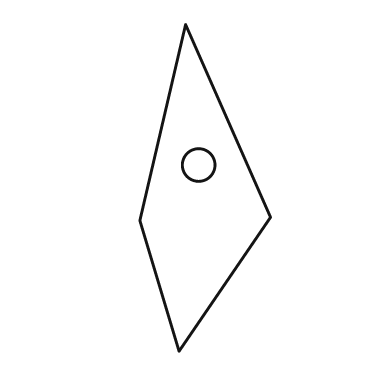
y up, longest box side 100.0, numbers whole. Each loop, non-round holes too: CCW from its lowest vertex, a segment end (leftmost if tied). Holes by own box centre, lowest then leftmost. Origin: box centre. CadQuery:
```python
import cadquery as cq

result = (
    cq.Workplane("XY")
    .moveTo(-8.0, -50.0)
    .lineTo(20.0, -9.0)
    .lineTo(-6.0, 50.0)
    .lineTo(-20.0, -10.0)
    .close()
    .moveTo(-2.0, 7.0)
    .circle(5.0)
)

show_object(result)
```